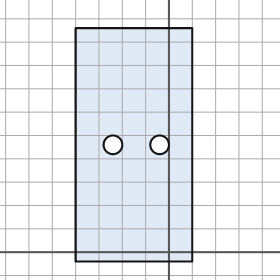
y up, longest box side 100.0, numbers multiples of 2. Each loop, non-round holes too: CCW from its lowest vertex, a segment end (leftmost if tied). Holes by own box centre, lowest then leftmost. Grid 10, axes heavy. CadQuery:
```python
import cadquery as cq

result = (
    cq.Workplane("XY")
    .moveTo(-40.0, -4.0)
    .lineTo(10.0, -4.0)
    .lineTo(10.0, 96.0)
    .lineTo(-40.0, 96.0)
    .close()
    .moveTo(-24.0, 46.0)
    .circle(4.0)
    .moveTo(-4.0, 46.0)
    .circle(4.0)
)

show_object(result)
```